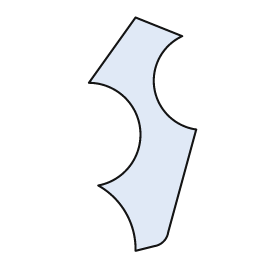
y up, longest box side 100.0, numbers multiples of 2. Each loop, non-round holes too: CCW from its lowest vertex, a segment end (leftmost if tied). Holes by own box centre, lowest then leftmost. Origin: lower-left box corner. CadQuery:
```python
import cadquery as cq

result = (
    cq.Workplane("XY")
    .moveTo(20.0, 0.0)
    .lineTo(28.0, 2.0)
    .threePointArc((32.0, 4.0), (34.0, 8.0))
    .lineTo(46.0, 52.0)
    .threePointArc((28.0, 70.0), (40.0, 92.0))
    .lineTo(20.0, 100.0)
    .lineTo(0.0, 72.0)
    .threePointArc((22.0, 52.0), (4.0, 28.0))
    .threePointArc((16.0, 16.0), (20.0, 0.0))
    .close()
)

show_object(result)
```